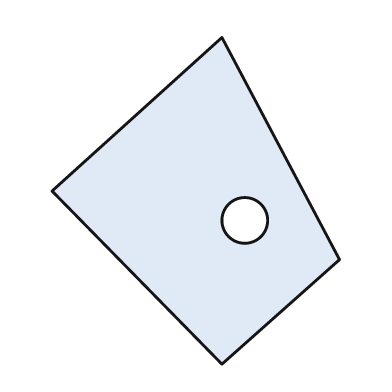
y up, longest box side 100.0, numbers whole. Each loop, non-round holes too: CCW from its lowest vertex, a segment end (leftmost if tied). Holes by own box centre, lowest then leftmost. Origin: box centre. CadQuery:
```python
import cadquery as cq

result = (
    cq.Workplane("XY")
    .moveTo(8.0, -50.0)
    .lineTo(44.0, -18.0)
    .lineTo(8.0, 50.0)
    .lineTo(-44.0, 3.0)
    .close()
    .moveTo(15.0, -6.0)
    .circle(7.0)
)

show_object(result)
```